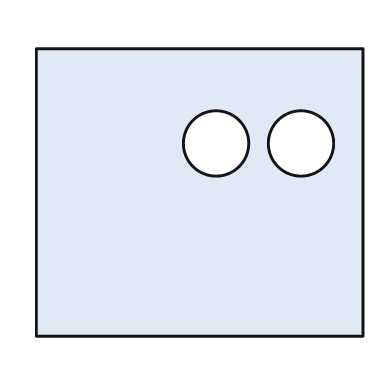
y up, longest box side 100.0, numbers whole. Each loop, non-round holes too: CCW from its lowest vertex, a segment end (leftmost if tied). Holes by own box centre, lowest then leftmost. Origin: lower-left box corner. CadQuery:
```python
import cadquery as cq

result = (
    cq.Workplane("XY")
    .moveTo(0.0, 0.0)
    .lineTo(100.0, 0.0)
    .lineTo(100.0, 88.0)
    .lineTo(0.0, 88.0)
    .close()
    .moveTo(55.0, 59.0)
    .circle(10.0)
    .moveTo(81.0, 59.0)
    .circle(10.0)
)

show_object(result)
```